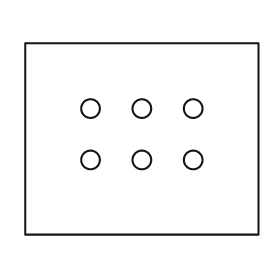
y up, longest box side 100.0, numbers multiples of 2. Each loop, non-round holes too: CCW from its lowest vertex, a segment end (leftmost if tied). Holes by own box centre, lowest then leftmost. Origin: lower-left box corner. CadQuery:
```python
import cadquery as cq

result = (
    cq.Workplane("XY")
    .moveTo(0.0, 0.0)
    .lineTo(100.0, 0.0)
    .lineTo(100.0, 82.0)
    .lineTo(0.0, 82.0)
    .close()
    .moveTo(28.0, 32.0)
    .circle(4.0)
    .moveTo(50.0, 32.0)
    .circle(4.0)
    .moveTo(72.0, 32.0)
    .circle(4.0)
    .moveTo(28.0, 54.0)
    .circle(4.0)
    .moveTo(50.0, 54.0)
    .circle(4.0)
    .moveTo(72.0, 54.0)
    .circle(4.0)
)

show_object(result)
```